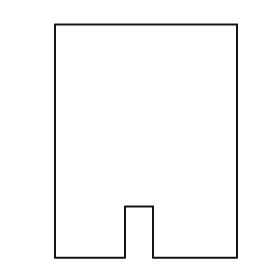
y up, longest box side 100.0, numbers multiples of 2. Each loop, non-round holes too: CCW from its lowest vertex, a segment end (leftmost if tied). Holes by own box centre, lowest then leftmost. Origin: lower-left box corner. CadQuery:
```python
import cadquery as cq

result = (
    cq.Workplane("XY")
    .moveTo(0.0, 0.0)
    .lineTo(30.0, 0.0)
    .lineTo(30.0, 22.0)
    .lineTo(42.0, 22.0)
    .lineTo(42.0, 0.0)
    .lineTo(78.0, 0.0)
    .lineTo(78.0, 100.0)
    .lineTo(0.0, 100.0)
    .close()
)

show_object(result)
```